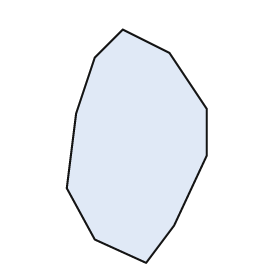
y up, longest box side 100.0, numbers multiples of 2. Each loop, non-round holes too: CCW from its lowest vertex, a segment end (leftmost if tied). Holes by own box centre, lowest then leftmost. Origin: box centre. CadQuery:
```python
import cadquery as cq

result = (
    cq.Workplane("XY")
    .moveTo(4.0, -50.0)
    .lineTo(16.0, -34.0)
    .lineTo(30.0, -4.0)
    .lineTo(30.0, 16.0)
    .lineTo(14.0, 40.0)
    .lineTo(-6.0, 50.0)
    .lineTo(-18.0, 38.0)
    .lineTo(-26.0, 14.0)
    .lineTo(-30.0, -18.0)
    .lineTo(-18.0, -40.0)
    .close()
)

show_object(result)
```